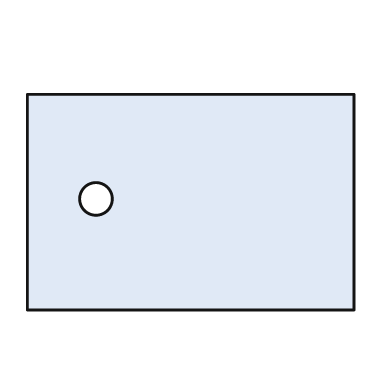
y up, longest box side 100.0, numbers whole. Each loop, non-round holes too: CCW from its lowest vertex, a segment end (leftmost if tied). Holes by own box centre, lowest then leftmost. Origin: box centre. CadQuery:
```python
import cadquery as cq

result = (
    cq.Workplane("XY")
    .moveTo(-50.0, -33.0)
    .lineTo(50.0, -33.0)
    .lineTo(50.0, 33.0)
    .lineTo(-50.0, 33.0)
    .close()
    .moveTo(-29.0, 1.0)
    .circle(5.0)
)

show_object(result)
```